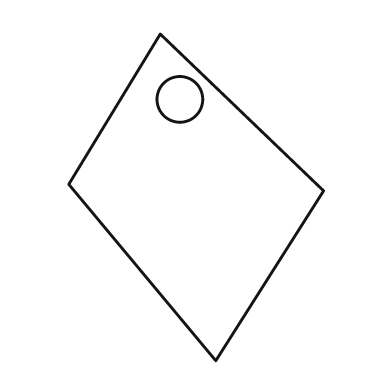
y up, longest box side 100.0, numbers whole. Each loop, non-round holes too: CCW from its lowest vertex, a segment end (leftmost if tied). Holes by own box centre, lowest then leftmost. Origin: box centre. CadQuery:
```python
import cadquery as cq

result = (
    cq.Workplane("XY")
    .moveTo(6.0, -50.0)
    .lineTo(39.0, 2.0)
    .lineTo(-11.0, 50.0)
    .lineTo(-39.0, 4.0)
    .close()
    .moveTo(-5.0, 30.0)
    .circle(7.0)
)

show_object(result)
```